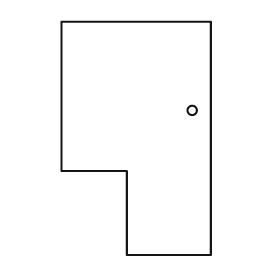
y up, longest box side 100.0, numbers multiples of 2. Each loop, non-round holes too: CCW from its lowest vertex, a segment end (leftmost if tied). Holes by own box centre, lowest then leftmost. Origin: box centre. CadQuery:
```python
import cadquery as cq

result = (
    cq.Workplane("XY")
    .moveTo(-4.0, -50.0)
    .lineTo(32.0, -50.0)
    .lineTo(32.0, 50.0)
    .lineTo(-32.0, 50.0)
    .lineTo(-32.0, -14.0)
    .lineTo(-4.0, -14.0)
    .close()
    .moveTo(24.0, 12.0)
    .circle(2.0)
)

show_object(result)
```